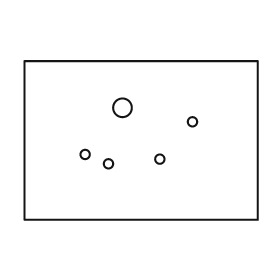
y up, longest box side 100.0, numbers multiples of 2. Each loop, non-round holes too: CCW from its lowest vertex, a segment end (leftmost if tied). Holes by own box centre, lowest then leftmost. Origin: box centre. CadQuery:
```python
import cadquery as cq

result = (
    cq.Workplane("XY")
    .moveTo(-50.0, -34.0)
    .lineTo(50.0, -34.0)
    .lineTo(50.0, 34.0)
    .lineTo(-50.0, 34.0)
    .close()
    .moveTo(-14.0, -10.0)
    .circle(2.0)
    .moveTo(8.0, -8.0)
    .circle(2.0)
    .moveTo(-24.0, -6.0)
    .circle(2.0)
    .moveTo(22.0, 8.0)
    .circle(2.0)
    .moveTo(-8.0, 14.0)
    .circle(4.0)
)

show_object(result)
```